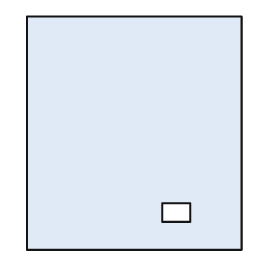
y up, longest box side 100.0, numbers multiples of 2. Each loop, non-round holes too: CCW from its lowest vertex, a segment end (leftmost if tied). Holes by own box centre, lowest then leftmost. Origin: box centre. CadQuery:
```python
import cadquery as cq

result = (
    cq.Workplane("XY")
    .moveTo(-46.0, -50.0)
    .lineTo(46.0, -50.0)
    .lineTo(46.0, 50.0)
    .lineTo(-46.0, 50.0)
    .close()
    .moveTo(12.0, -38.0)
    .lineTo(24.0, -38.0)
    .lineTo(24.0, -30.0)
    .lineTo(12.0, -30.0)
    .close()
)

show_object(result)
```